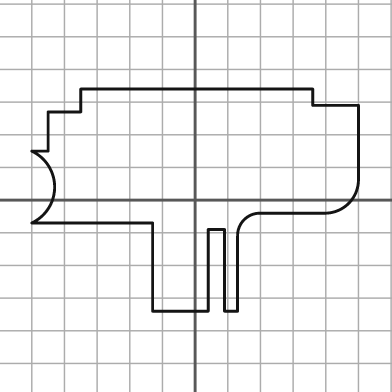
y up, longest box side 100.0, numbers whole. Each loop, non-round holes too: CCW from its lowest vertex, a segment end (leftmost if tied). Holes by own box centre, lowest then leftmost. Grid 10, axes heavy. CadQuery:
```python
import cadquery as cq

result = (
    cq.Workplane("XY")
    .moveTo(-13.0, -34.0)
    .lineTo(4.0, -34.0)
    .lineTo(4.0, -9.0)
    .lineTo(9.0, -9.0)
    .lineTo(9.0, -34.0)
    .lineTo(13.0, -34.0)
    .lineTo(13.0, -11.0)
    .threePointArc((15.0, -6.0), (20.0, -4.0))
    .lineTo(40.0, -4.0)
    .threePointArc((47.0, -1.0), (50.0, 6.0))
    .lineTo(50.0, 29.0)
    .lineTo(36.0, 29.0)
    .lineTo(36.0, 34.0)
    .lineTo(-35.0, 34.0)
    .lineTo(-35.0, 27.0)
    .lineTo(-45.0, 27.0)
    .lineTo(-45.0, 15.0)
    .lineTo(-50.0, 15.0)
    .threePointArc((-43.0, 4.0), (-50.0, -7.0))
    .lineTo(-13.0, -7.0)
    .close()
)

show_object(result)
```